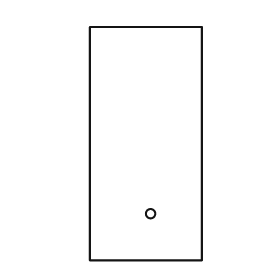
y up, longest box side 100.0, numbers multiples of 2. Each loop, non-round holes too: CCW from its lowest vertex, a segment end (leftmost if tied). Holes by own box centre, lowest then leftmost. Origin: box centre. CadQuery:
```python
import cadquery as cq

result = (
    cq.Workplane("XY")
    .moveTo(-24.0, -50.0)
    .lineTo(24.0, -50.0)
    .lineTo(24.0, 50.0)
    .lineTo(-24.0, 50.0)
    .close()
    .moveTo(2.0, -30.0)
    .circle(2.0)
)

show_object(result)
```